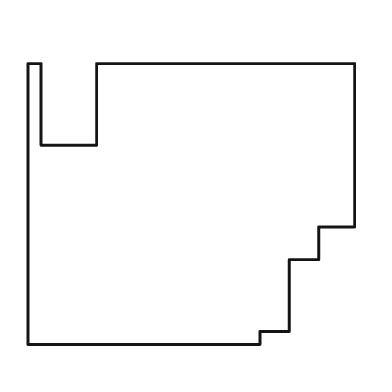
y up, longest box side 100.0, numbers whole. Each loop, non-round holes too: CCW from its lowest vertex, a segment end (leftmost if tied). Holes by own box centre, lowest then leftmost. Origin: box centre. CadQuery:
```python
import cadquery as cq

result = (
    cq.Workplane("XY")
    .moveTo(-50.0, -43.0)
    .lineTo(21.0, -43.0)
    .lineTo(21.0, -39.0)
    .lineTo(30.0, -39.0)
    .lineTo(30.0, -17.0)
    .lineTo(39.0, -17.0)
    .lineTo(39.0, -7.0)
    .lineTo(50.0, -7.0)
    .lineTo(50.0, 43.0)
    .lineTo(-29.0, 43.0)
    .lineTo(-29.0, 18.0)
    .lineTo(-46.0, 18.0)
    .lineTo(-46.0, 43.0)
    .lineTo(-50.0, 43.0)
    .close()
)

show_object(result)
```